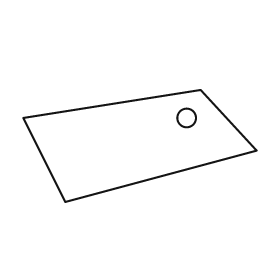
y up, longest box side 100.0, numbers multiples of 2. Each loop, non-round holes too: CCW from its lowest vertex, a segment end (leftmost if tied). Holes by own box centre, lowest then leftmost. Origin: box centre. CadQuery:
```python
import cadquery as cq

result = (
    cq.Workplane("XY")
    .moveTo(-32.0, -24.0)
    .lineTo(50.0, -2.0)
    .lineTo(26.0, 24.0)
    .lineTo(-50.0, 12.0)
    .close()
    .moveTo(20.0, 12.0)
    .circle(4.0)
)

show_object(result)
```